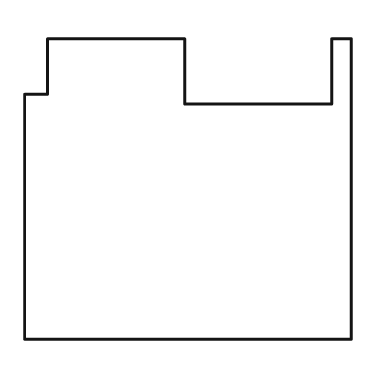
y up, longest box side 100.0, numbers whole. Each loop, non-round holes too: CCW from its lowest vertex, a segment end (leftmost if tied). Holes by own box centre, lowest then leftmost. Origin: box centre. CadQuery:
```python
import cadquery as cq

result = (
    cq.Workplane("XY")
    .moveTo(-50.0, -46.0)
    .lineTo(50.0, -46.0)
    .lineTo(50.0, 46.0)
    .lineTo(44.0, 46.0)
    .lineTo(44.0, 26.0)
    .lineTo(-1.0, 26.0)
    .lineTo(-1.0, 46.0)
    .lineTo(-43.0, 46.0)
    .lineTo(-43.0, 29.0)
    .lineTo(-50.0, 29.0)
    .close()
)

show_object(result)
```